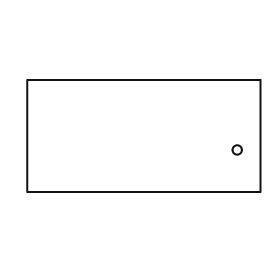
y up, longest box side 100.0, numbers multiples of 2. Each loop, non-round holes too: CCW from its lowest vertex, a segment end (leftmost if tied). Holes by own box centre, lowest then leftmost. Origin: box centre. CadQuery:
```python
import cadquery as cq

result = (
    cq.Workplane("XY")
    .moveTo(-50.0, -24.0)
    .lineTo(50.0, -24.0)
    .lineTo(50.0, 24.0)
    .lineTo(-50.0, 24.0)
    .close()
    .moveTo(40.0, -6.0)
    .circle(2.0)
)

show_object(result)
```